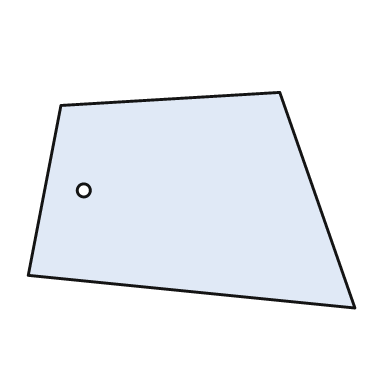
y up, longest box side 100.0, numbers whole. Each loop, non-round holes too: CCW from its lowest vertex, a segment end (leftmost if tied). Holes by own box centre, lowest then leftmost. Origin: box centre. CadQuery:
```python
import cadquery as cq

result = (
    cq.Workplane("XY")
    .moveTo(50.0, -33.0)
    .lineTo(27.0, 33.0)
    .lineTo(-40.0, 29.0)
    .lineTo(-50.0, -23.0)
    .close()
    .moveTo(-33.0, 3.0)
    .circle(2.0)
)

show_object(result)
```